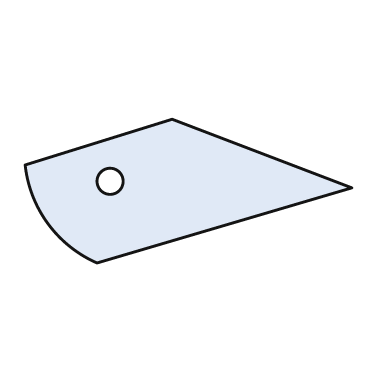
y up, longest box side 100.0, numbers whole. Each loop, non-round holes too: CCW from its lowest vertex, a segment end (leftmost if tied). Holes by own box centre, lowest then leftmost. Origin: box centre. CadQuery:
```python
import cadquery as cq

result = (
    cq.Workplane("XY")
    .moveTo(-28.0, -22.0)
    .lineTo(50.0, 1.0)
    .lineTo(-5.0, 22.0)
    .lineTo(-50.0, 8.0)
    .threePointArc((-43.0, -10.0), (-28.0, -22.0))
    .close()
    .moveTo(-24.0, 3.0)
    .circle(4.0)
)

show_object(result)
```